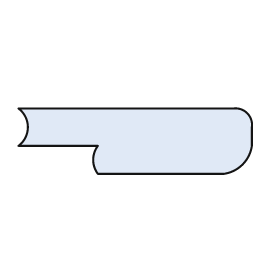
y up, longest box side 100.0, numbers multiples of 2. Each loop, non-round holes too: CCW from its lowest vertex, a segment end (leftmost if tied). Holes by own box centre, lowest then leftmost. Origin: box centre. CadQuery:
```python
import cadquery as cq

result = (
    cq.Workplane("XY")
    .moveTo(-16.0, -14.0)
    .lineTo(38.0, -14.0)
    .threePointArc((46.0, -10.0), (50.0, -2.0))
    .lineTo(50.0, 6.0)
    .threePointArc((48.0, 12.0), (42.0, 14.0))
    .lineTo(-50.0, 14.0)
    .threePointArc((-46.0, 6.0), (-50.0, -2.0))
    .lineTo(-16.0, -2.0)
    .threePointArc((-18.0, -8.0), (-16.0, -14.0))
    .close()
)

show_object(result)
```